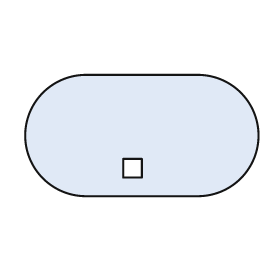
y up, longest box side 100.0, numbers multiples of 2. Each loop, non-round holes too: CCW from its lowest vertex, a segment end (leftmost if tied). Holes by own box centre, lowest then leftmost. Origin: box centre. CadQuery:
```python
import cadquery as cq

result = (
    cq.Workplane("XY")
    .moveTo(-24.0, -26.0)
    .lineTo(24.0, -26.0)
    .threePointArc((50.0, 0.0), (24.0, 26.0))
    .lineTo(-24.0, 26.0)
    .threePointArc((-50.0, 0.0), (-24.0, -26.0))
    .close()
    .moveTo(-8.0, -18.0)
    .lineTo(0.0, -18.0)
    .lineTo(0.0, -10.0)
    .lineTo(-8.0, -10.0)
    .close()
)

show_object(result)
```